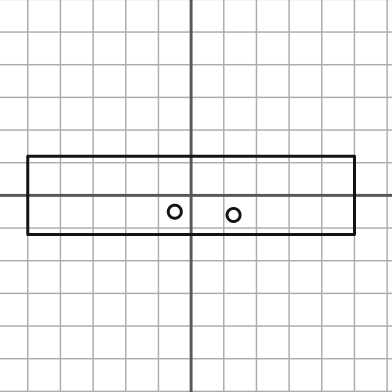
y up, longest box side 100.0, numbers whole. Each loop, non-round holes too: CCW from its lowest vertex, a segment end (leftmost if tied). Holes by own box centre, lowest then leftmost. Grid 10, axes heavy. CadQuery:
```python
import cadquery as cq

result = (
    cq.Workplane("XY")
    .moveTo(-50.0, -12.0)
    .lineTo(50.0, -12.0)
    .lineTo(50.0, 12.0)
    .lineTo(-50.0, 12.0)
    .close()
    .moveTo(13.0, -6.0)
    .circle(2.0)
    .moveTo(-5.0, -5.0)
    .circle(2.0)
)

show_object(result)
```